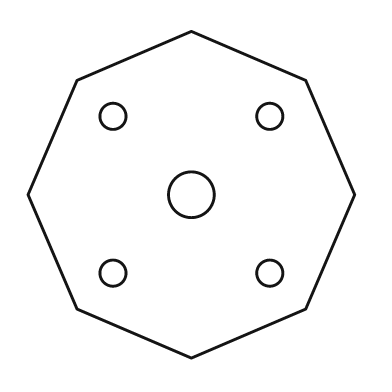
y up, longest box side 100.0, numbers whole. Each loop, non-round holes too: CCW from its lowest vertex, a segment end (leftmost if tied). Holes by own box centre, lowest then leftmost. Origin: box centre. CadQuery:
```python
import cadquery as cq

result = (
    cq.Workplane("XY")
    .moveTo(0.0, -50.0)
    .lineTo(35.0, -35.0)
    .lineTo(50.0, 0.0)
    .lineTo(35.0, 35.0)
    .lineTo(0.0, 50.0)
    .lineTo(-35.0, 35.0)
    .lineTo(-50.0, 0.0)
    .lineTo(-35.0, -35.0)
    .close()
    .moveTo(-24.0, -24.0)
    .circle(4.0)
    .moveTo(24.0, -24.0)
    .circle(4.0)
    .moveTo(0.0, 0.0)
    .circle(7.0)
    .moveTo(-24.0, 24.0)
    .circle(4.0)
    .moveTo(24.0, 24.0)
    .circle(4.0)
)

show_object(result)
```